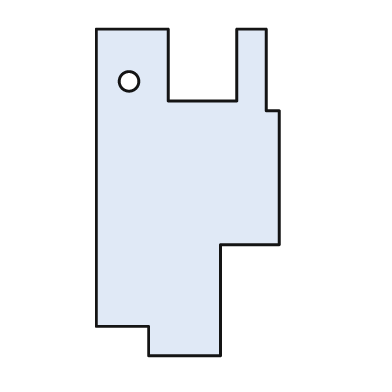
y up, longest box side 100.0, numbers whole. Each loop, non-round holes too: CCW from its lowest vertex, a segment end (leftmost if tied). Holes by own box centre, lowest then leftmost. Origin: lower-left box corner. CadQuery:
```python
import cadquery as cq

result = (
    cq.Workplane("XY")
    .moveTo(16.0, 0.0)
    .lineTo(38.0, 0.0)
    .lineTo(38.0, 34.0)
    .lineTo(56.0, 34.0)
    .lineTo(56.0, 75.0)
    .lineTo(52.0, 75.0)
    .lineTo(52.0, 100.0)
    .lineTo(43.0, 100.0)
    .lineTo(43.0, 78.0)
    .lineTo(22.0, 78.0)
    .lineTo(22.0, 100.0)
    .lineTo(0.0, 100.0)
    .lineTo(0.0, 9.0)
    .lineTo(16.0, 9.0)
    .close()
    .moveTo(10.0, 84.0)
    .circle(3.0)
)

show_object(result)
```